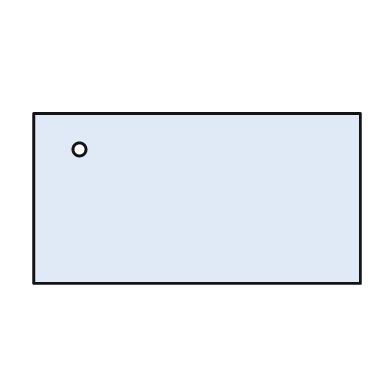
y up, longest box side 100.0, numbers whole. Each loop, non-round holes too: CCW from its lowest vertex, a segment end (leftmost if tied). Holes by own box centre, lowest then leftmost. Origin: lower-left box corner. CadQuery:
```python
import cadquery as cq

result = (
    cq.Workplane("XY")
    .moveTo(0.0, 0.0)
    .lineTo(100.0, 0.0)
    .lineTo(100.0, 52.0)
    .lineTo(0.0, 52.0)
    .close()
    .moveTo(14.0, 41.0)
    .circle(2.0)
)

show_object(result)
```